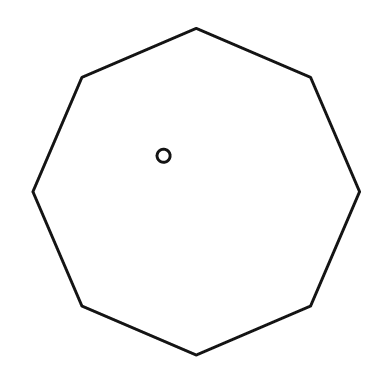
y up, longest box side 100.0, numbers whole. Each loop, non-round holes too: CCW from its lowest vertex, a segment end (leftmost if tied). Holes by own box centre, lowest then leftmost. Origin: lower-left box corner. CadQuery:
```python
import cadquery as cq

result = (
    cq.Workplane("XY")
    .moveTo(50.0, 0.0)
    .lineTo(85.0, 15.0)
    .lineTo(100.0, 50.0)
    .lineTo(85.0, 85.0)
    .lineTo(50.0, 100.0)
    .lineTo(15.0, 85.0)
    .lineTo(0.0, 50.0)
    .lineTo(15.0, 15.0)
    .close()
    .moveTo(40.0, 61.0)
    .circle(2.0)
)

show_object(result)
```